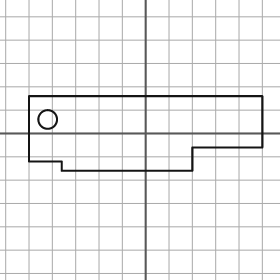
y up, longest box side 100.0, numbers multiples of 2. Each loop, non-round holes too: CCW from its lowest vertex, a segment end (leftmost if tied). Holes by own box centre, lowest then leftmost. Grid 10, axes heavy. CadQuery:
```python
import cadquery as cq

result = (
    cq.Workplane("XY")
    .moveTo(-36.0, -16.0)
    .lineTo(20.0, -16.0)
    .lineTo(20.0, -6.0)
    .lineTo(50.0, -6.0)
    .lineTo(50.0, 16.0)
    .lineTo(-50.0, 16.0)
    .lineTo(-50.0, -12.0)
    .lineTo(-36.0, -12.0)
    .close()
    .moveTo(-42.0, 6.0)
    .circle(4.0)
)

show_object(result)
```